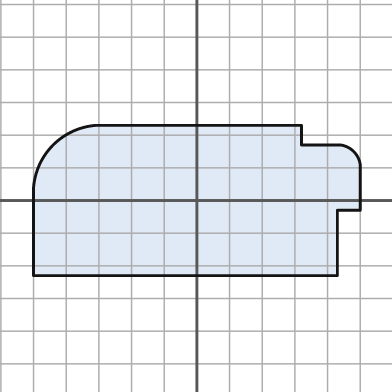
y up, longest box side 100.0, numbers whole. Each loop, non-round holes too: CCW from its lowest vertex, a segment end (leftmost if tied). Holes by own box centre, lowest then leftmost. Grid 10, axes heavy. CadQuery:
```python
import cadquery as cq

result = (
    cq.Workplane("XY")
    .moveTo(-50.0, -23.0)
    .lineTo(43.0, -23.0)
    .lineTo(43.0, -3.0)
    .lineTo(50.0, -3.0)
    .lineTo(50.0, 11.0)
    .threePointArc((48.0, 15.0), (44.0, 17.0))
    .lineTo(32.0, 17.0)
    .lineTo(32.0, 23.0)
    .lineTo(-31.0, 23.0)
    .threePointArc((-44.0, 17.0), (-50.0, 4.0))
    .close()
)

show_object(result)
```